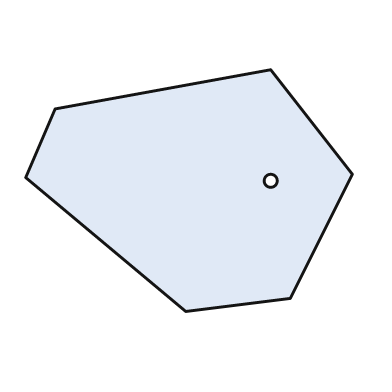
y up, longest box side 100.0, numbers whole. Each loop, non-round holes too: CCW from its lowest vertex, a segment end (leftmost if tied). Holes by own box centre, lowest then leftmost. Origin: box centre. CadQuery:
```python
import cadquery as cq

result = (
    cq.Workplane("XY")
    .moveTo(-1.0, -37.0)
    .lineTo(31.0, -33.0)
    .lineTo(50.0, 5.0)
    .lineTo(25.0, 37.0)
    .lineTo(-41.0, 25.0)
    .lineTo(-50.0, 4.0)
    .close()
    .moveTo(25.0, 3.0)
    .circle(2.0)
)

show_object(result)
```